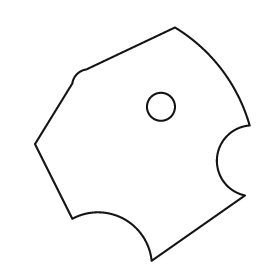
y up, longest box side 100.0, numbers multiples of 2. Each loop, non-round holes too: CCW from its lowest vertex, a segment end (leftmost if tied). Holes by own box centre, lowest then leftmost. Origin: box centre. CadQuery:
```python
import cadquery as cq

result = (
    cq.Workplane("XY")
    .moveTo(4.0, -50.0)
    .lineTo(44.0, -22.0)
    .threePointArc((32.0, -6.0), (46.0, 8.0))
    .threePointArc((34.0, 32.0), (14.0, 50.0))
    .lineTo(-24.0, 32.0)
    .threePointArc((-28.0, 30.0), (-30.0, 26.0))
    .lineTo(-46.0, 0.0)
    .lineTo(-30.0, -32.0)
    .threePointArc((-8.0, -32.0), (4.0, -50.0))
    .close()
    .moveTo(8.0, 16.0)
    .circle(6.0)
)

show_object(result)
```